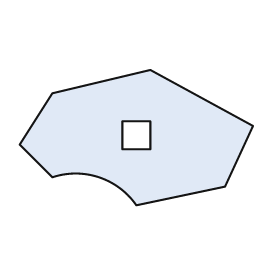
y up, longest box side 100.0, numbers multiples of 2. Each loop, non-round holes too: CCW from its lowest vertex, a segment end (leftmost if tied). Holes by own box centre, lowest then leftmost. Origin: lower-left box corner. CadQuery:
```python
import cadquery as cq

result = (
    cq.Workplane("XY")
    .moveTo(50.0, 0.0)
    .lineTo(88.0, 8.0)
    .lineTo(100.0, 34.0)
    .lineTo(56.0, 58.0)
    .lineTo(14.0, 48.0)
    .lineTo(0.0, 26.0)
    .lineTo(14.0, 12.0)
    .threePointArc((34.0, 12.0), (50.0, 0.0))
    .close()
    .moveTo(44.0, 24.0)
    .lineTo(56.0, 24.0)
    .lineTo(56.0, 36.0)
    .lineTo(44.0, 36.0)
    .close()
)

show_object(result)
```